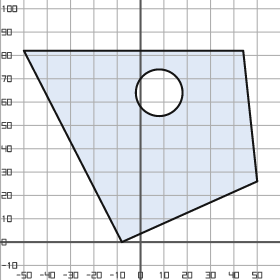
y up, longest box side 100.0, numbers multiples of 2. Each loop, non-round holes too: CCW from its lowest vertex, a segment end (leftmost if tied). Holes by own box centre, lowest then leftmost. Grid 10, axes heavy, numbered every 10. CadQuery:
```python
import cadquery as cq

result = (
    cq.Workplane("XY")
    .moveTo(-8.0, 0.0)
    .lineTo(50.0, 26.0)
    .lineTo(44.0, 82.0)
    .lineTo(-50.0, 82.0)
    .close()
    .moveTo(8.0, 64.0)
    .circle(10.0)
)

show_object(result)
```